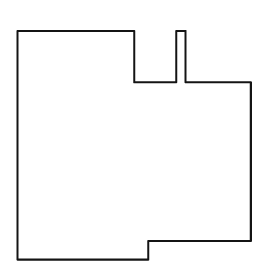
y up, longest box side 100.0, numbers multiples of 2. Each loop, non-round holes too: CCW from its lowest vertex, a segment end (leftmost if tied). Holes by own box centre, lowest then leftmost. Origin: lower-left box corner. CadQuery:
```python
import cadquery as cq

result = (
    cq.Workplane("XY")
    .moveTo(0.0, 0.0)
    .lineTo(56.0, 0.0)
    .lineTo(56.0, 8.0)
    .lineTo(100.0, 8.0)
    .lineTo(100.0, 76.0)
    .lineTo(72.0, 76.0)
    .lineTo(72.0, 98.0)
    .lineTo(68.0, 98.0)
    .lineTo(68.0, 76.0)
    .lineTo(50.0, 76.0)
    .lineTo(50.0, 98.0)
    .lineTo(0.0, 98.0)
    .close()
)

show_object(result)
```